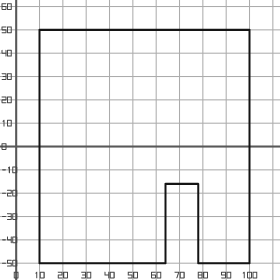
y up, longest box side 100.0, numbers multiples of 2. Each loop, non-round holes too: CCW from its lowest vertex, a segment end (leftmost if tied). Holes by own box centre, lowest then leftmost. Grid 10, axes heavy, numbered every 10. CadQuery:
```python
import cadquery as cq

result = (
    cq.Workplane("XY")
    .moveTo(10.0, -50.0)
    .lineTo(64.0, -50.0)
    .lineTo(64.0, -16.0)
    .lineTo(78.0, -16.0)
    .lineTo(78.0, -50.0)
    .lineTo(100.0, -50.0)
    .lineTo(100.0, 50.0)
    .lineTo(10.0, 50.0)
    .close()
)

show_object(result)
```